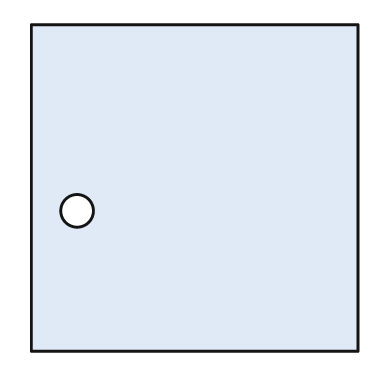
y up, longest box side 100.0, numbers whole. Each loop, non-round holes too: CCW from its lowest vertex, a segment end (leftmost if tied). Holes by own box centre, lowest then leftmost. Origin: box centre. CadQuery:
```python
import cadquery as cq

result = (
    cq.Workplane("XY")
    .moveTo(-50.0, -50.0)
    .lineTo(50.0, -50.0)
    .lineTo(50.0, 50.0)
    .lineTo(-50.0, 50.0)
    .close()
    .moveTo(-36.0, -7.0)
    .circle(5.0)
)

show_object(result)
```